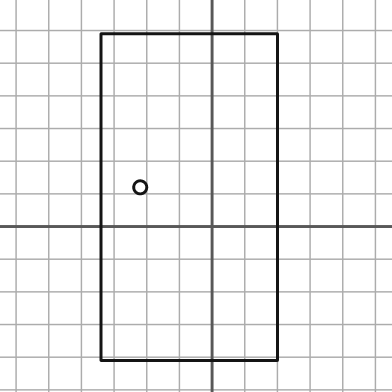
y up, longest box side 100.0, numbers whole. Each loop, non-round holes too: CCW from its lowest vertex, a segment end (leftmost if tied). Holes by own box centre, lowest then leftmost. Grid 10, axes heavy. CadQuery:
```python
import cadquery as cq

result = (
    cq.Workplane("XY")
    .moveTo(-34.0, -41.0)
    .lineTo(20.0, -41.0)
    .lineTo(20.0, 59.0)
    .lineTo(-34.0, 59.0)
    .close()
    .moveTo(-22.0, 12.0)
    .circle(2.0)
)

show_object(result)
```